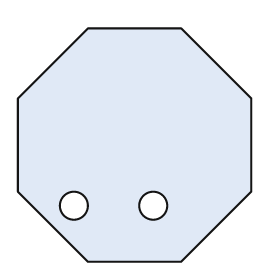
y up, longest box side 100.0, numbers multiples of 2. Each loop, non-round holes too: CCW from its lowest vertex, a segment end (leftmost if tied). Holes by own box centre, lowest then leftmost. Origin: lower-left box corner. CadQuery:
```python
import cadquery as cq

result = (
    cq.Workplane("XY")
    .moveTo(30.0, 0.0)
    .lineTo(70.0, 0.0)
    .lineTo(100.0, 30.0)
    .lineTo(100.0, 70.0)
    .lineTo(70.0, 100.0)
    .lineTo(30.0, 100.0)
    .lineTo(0.0, 70.0)
    .lineTo(0.0, 30.0)
    .close()
    .moveTo(24.0, 24.0)
    .circle(6.0)
    .moveTo(58.0, 24.0)
    .circle(6.0)
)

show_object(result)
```